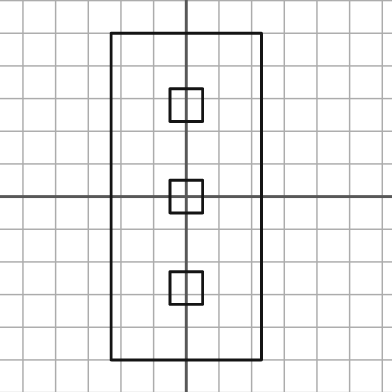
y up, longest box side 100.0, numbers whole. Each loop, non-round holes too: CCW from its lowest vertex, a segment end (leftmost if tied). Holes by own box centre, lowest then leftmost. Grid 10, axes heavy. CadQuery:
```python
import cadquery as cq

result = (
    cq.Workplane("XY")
    .moveTo(-23.0, -50.0)
    .lineTo(23.0, -50.0)
    .lineTo(23.0, 50.0)
    .lineTo(-23.0, 50.0)
    .close()
    .moveTo(-5.0, -33.0)
    .lineTo(5.0, -33.0)
    .lineTo(5.0, -23.0)
    .lineTo(-5.0, -23.0)
    .close()
    .moveTo(-5.0, -5.0)
    .lineTo(5.0, -5.0)
    .lineTo(5.0, 5.0)
    .lineTo(-5.0, 5.0)
    .close()
    .moveTo(-5.0, 23.0)
    .lineTo(5.0, 23.0)
    .lineTo(5.0, 33.0)
    .lineTo(-5.0, 33.0)
    .close()
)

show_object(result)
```